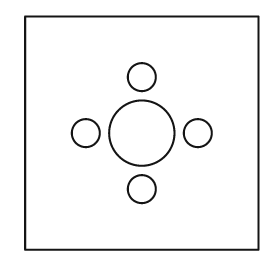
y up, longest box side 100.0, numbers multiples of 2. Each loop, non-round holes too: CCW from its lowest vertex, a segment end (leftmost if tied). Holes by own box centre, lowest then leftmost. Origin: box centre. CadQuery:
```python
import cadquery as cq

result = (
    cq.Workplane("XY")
    .moveTo(-50.0, -50.0)
    .lineTo(50.0, -50.0)
    .lineTo(50.0, 50.0)
    .lineTo(-50.0, 50.0)
    .close()
    .moveTo(0.0, -24.0)
    .circle(6.0)
    .moveTo(-24.0, 0.0)
    .circle(6.0)
    .moveTo(0.0, 0.0)
    .circle(14.0)
    .moveTo(24.0, 0.0)
    .circle(6.0)
    .moveTo(0.0, 24.0)
    .circle(6.0)
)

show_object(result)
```